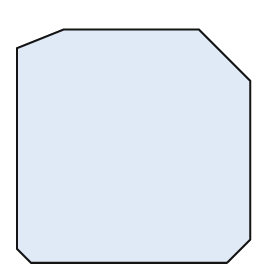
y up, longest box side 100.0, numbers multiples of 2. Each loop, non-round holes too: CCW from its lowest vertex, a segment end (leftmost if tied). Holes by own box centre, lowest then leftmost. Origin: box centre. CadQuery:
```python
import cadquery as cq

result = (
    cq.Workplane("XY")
    .moveTo(-44.0, -50.0)
    .lineTo(40.0, -50.0)
    .lineTo(50.0, -40.0)
    .lineTo(50.0, 28.0)
    .lineTo(28.0, 50.0)
    .lineTo(-30.0, 50.0)
    .lineTo(-50.0, 42.0)
    .lineTo(-50.0, -44.0)
    .close()
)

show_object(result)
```